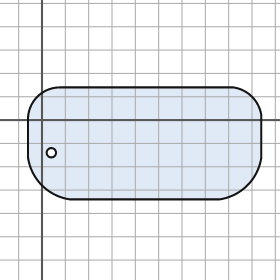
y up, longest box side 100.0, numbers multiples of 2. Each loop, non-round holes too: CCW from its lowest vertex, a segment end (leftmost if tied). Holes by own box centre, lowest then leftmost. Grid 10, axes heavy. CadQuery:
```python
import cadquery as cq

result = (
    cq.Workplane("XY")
    .moveTo(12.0, -34.0)
    .lineTo(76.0, -34.0)
    .threePointArc((88.0, -28.0), (94.0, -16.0))
    .lineTo(94.0, 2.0)
    .threePointArc((90.0, 10.0), (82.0, 14.0))
    .lineTo(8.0, 14.0)
    .threePointArc((-2.0, 10.0), (-6.0, 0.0))
    .lineTo(-6.0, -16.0)
    .threePointArc((0.0, -28.0), (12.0, -34.0))
    .close()
    .moveTo(4.0, -14.0)
    .circle(2.0)
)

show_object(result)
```